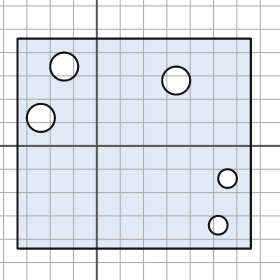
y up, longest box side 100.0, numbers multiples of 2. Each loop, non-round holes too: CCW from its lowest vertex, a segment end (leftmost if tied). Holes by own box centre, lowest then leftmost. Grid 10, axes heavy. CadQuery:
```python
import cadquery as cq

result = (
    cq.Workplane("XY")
    .moveTo(-34.0, -44.0)
    .lineTo(66.0, -44.0)
    .lineTo(66.0, 46.0)
    .lineTo(-34.0, 46.0)
    .close()
    .moveTo(52.0, -34.0)
    .circle(4.0)
    .moveTo(56.0, -14.0)
    .circle(4.0)
    .moveTo(-24.0, 12.0)
    .circle(6.0)
    .moveTo(34.0, 28.0)
    .circle(6.0)
    .moveTo(-14.0, 34.0)
    .circle(6.0)
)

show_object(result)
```